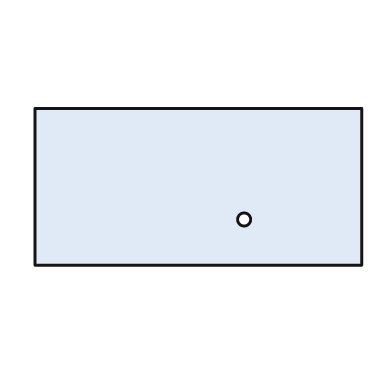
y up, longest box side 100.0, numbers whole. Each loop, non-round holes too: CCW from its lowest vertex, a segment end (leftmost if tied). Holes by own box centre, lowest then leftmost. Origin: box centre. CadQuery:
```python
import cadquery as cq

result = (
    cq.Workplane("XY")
    .moveTo(-50.0, -24.0)
    .lineTo(50.0, -24.0)
    .lineTo(50.0, 24.0)
    .lineTo(-50.0, 24.0)
    .close()
    .moveTo(14.0, -10.0)
    .circle(2.0)
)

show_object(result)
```